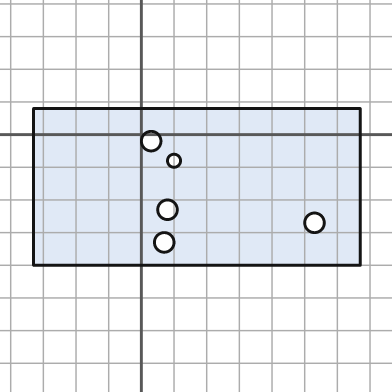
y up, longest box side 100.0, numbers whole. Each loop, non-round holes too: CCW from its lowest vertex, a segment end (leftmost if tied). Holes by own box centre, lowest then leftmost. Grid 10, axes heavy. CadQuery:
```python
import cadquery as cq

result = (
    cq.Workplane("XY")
    .moveTo(-33.0, -40.0)
    .lineTo(67.0, -40.0)
    .lineTo(67.0, 8.0)
    .lineTo(-33.0, 8.0)
    .close()
    .moveTo(7.0, -33.0)
    .circle(3.0)
    .moveTo(53.0, -27.0)
    .circle(3.0)
    .moveTo(8.0, -23.0)
    .circle(3.0)
    .moveTo(10.0, -8.0)
    .circle(2.0)
    .moveTo(3.0, -2.0)
    .circle(3.0)
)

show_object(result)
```